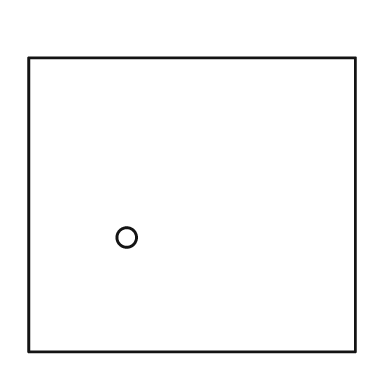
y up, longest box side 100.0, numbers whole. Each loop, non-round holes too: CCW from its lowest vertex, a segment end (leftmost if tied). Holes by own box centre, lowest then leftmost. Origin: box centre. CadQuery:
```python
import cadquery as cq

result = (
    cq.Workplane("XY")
    .moveTo(-50.0, -45.0)
    .lineTo(50.0, -45.0)
    .lineTo(50.0, 45.0)
    .lineTo(-50.0, 45.0)
    .close()
    .moveTo(-20.0, -10.0)
    .circle(3.0)
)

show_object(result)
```